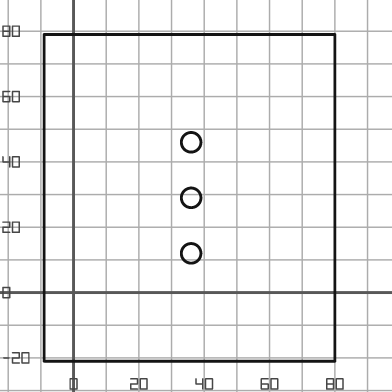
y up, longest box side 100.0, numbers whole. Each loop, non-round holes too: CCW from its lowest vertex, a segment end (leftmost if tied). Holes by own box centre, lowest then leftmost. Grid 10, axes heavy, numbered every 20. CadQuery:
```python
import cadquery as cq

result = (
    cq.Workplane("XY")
    .moveTo(-9.0, -21.0)
    .lineTo(80.0, -21.0)
    .lineTo(80.0, 79.0)
    .lineTo(-9.0, 79.0)
    .close()
    .moveTo(36.0, 12.0)
    .circle(3.0)
    .moveTo(36.0, 29.0)
    .circle(3.0)
    .moveTo(36.0, 46.0)
    .circle(3.0)
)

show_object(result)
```